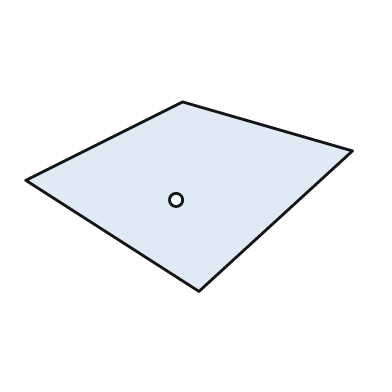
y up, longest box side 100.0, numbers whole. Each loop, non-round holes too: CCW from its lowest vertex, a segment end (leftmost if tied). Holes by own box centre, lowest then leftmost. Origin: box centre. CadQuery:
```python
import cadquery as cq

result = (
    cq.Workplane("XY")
    .moveTo(3.0, -29.0)
    .lineTo(50.0, 14.0)
    .lineTo(-2.0, 29.0)
    .lineTo(-50.0, 5.0)
    .close()
    .moveTo(-4.0, -1.0)
    .circle(2.0)
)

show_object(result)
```